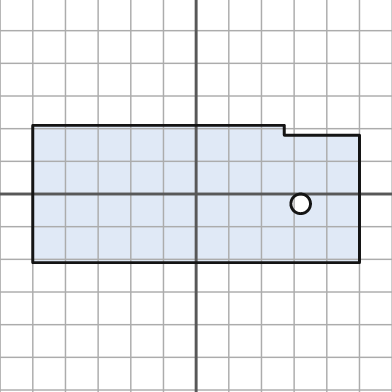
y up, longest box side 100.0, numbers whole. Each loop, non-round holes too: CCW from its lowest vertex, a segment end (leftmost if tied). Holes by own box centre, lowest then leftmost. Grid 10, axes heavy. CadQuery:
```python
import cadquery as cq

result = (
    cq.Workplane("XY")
    .moveTo(-50.0, -21.0)
    .lineTo(50.0, -21.0)
    .lineTo(50.0, 18.0)
    .lineTo(27.0, 18.0)
    .lineTo(27.0, 21.0)
    .lineTo(-50.0, 21.0)
    .close()
    .moveTo(32.0, -3.0)
    .circle(3.0)
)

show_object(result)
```